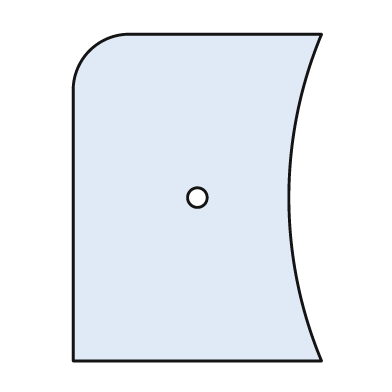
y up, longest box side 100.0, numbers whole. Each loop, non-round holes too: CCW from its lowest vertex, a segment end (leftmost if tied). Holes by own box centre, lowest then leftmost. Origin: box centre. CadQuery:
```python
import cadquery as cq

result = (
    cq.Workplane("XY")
    .moveTo(-38.0, -50.0)
    .lineTo(38.0, -50.0)
    .threePointArc((28.0, 0.0), (38.0, 50.0))
    .lineTo(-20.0, 50.0)
    .threePointArc((-33.0, 45.0), (-38.0, 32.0))
    .close()
    .moveTo(0.0, 0.0)
    .circle(3.0)
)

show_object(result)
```